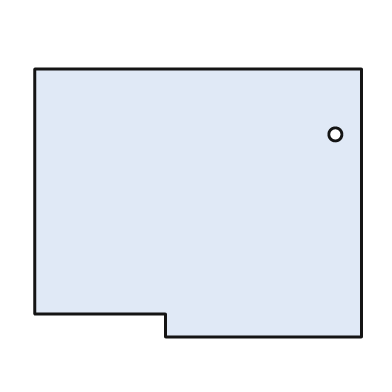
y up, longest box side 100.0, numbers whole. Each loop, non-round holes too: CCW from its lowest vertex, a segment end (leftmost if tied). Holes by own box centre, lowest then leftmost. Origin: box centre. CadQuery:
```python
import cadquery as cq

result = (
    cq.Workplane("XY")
    .moveTo(-10.0, -41.0)
    .lineTo(50.0, -41.0)
    .lineTo(50.0, 41.0)
    .lineTo(-50.0, 41.0)
    .lineTo(-50.0, -34.0)
    .lineTo(-10.0, -34.0)
    .close()
    .moveTo(42.0, 21.0)
    .circle(2.0)
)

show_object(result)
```